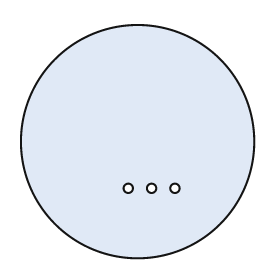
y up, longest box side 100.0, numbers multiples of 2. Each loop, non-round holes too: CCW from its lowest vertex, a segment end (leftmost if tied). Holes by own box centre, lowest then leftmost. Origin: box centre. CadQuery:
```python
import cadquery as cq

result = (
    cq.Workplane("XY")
    .moveTo(0.0, 0.0)
    .circle(50.0)
    .moveTo(-4.0, -20.0)
    .circle(2.0)
    .moveTo(6.0, -20.0)
    .circle(2.0)
    .moveTo(16.0, -20.0)
    .circle(2.0)
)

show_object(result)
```